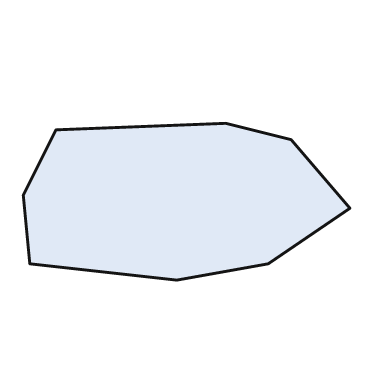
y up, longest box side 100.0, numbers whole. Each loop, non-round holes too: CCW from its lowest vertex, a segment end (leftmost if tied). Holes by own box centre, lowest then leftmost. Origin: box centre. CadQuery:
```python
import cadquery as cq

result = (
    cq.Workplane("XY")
    .moveTo(-3.0, -24.0)
    .lineTo(25.0, -19.0)
    .lineTo(50.0, -2.0)
    .lineTo(32.0, 19.0)
    .lineTo(12.0, 24.0)
    .lineTo(-40.0, 22.0)
    .lineTo(-50.0, 2.0)
    .lineTo(-48.0, -19.0)
    .close()
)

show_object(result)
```